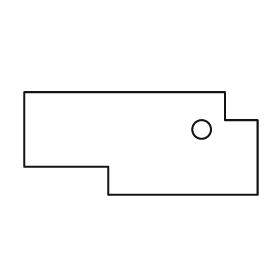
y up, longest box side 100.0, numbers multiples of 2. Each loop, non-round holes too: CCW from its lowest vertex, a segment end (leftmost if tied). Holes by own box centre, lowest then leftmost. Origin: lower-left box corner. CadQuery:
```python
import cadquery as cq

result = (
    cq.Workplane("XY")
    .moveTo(36.0, 0.0)
    .lineTo(100.0, 0.0)
    .lineTo(100.0, 32.0)
    .lineTo(86.0, 32.0)
    .lineTo(86.0, 44.0)
    .lineTo(0.0, 44.0)
    .lineTo(0.0, 12.0)
    .lineTo(36.0, 12.0)
    .close()
    .moveTo(76.0, 28.0)
    .circle(4.0)
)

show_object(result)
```